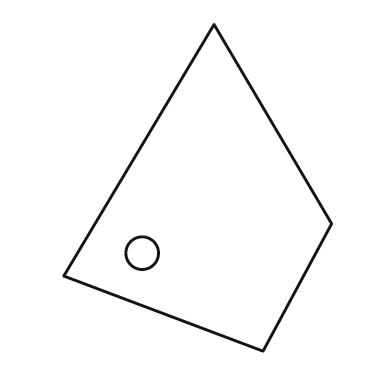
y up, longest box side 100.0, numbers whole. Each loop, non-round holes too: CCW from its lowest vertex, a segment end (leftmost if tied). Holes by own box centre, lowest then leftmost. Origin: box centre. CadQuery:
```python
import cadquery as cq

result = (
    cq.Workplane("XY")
    .moveTo(20.0, -50.0)
    .lineTo(41.0, -11.0)
    .lineTo(5.0, 50.0)
    .lineTo(-41.0, -27.0)
    .close()
    .moveTo(-17.0, -20.0)
    .circle(5.0)
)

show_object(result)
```